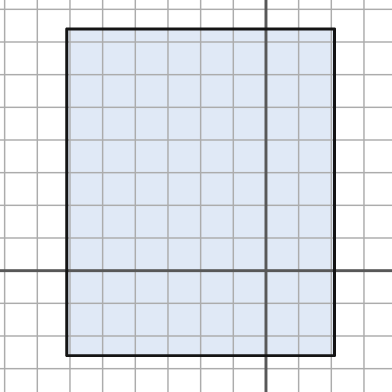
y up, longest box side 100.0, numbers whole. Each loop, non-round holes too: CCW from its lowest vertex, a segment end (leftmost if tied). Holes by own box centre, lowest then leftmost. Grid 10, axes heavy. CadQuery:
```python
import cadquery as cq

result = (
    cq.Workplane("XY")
    .moveTo(-61.0, -26.0)
    .lineTo(21.0, -26.0)
    .lineTo(21.0, 74.0)
    .lineTo(-61.0, 74.0)
    .close()
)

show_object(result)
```